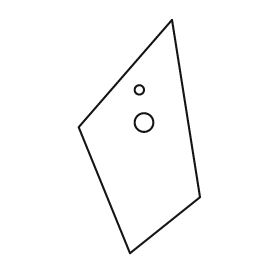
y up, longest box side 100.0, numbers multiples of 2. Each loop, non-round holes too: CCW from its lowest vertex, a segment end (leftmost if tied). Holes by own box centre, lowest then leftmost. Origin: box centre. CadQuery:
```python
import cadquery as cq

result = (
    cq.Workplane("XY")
    .moveTo(-4.0, -50.0)
    .lineTo(26.0, -26.0)
    .lineTo(14.0, 50.0)
    .lineTo(-26.0, 4.0)
    .close()
    .moveTo(2.0, 6.0)
    .circle(4.0)
    .moveTo(0.0, 20.0)
    .circle(2.0)
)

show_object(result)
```